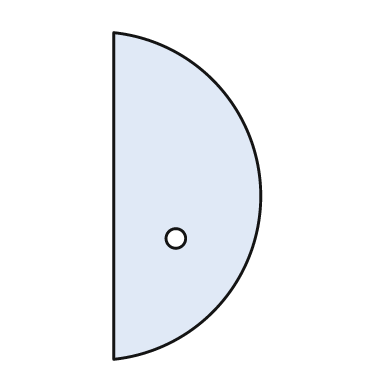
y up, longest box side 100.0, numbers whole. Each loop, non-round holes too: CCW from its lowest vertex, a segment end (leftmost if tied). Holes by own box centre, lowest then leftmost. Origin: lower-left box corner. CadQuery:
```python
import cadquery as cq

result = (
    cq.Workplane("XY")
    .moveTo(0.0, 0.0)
    .threePointArc((45.0, 50.0), (0.0, 100.0))
    .close()
    .moveTo(19.0, 37.0)
    .circle(3.0)
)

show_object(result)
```